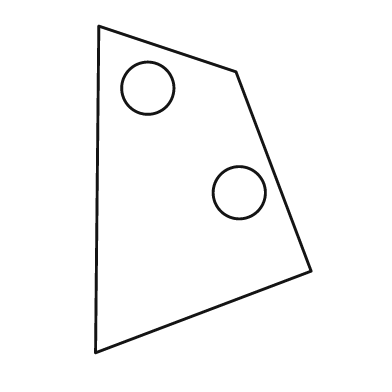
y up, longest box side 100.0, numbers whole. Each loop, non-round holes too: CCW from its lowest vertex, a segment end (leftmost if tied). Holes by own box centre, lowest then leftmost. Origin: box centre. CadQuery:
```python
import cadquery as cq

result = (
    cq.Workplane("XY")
    .moveTo(-33.0, -50.0)
    .lineTo(33.0, -25.0)
    .lineTo(10.0, 36.0)
    .lineTo(-32.0, 50.0)
    .close()
    .moveTo(11.0, -1.0)
    .circle(8.0)
    .moveTo(-17.0, 31.0)
    .circle(8.0)
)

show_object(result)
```